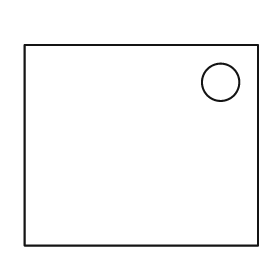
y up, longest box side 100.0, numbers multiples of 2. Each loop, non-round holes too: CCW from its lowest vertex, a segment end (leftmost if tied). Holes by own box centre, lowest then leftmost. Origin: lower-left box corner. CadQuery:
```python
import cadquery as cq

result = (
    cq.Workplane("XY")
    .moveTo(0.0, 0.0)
    .lineTo(100.0, 0.0)
    .lineTo(100.0, 86.0)
    .lineTo(0.0, 86.0)
    .close()
    .moveTo(84.0, 70.0)
    .circle(8.0)
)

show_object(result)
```